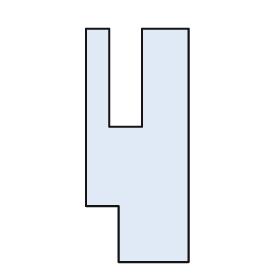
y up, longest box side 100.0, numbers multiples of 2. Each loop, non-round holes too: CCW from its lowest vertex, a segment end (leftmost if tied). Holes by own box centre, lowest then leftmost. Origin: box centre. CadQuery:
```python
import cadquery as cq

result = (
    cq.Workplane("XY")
    .moveTo(-8.0, -50.0)
    .lineTo(22.0, -50.0)
    .lineTo(22.0, 50.0)
    .lineTo(2.0, 50.0)
    .lineTo(2.0, 8.0)
    .lineTo(-12.0, 8.0)
    .lineTo(-12.0, 50.0)
    .lineTo(-22.0, 50.0)
    .lineTo(-22.0, -26.0)
    .lineTo(-8.0, -26.0)
    .close()
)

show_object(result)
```